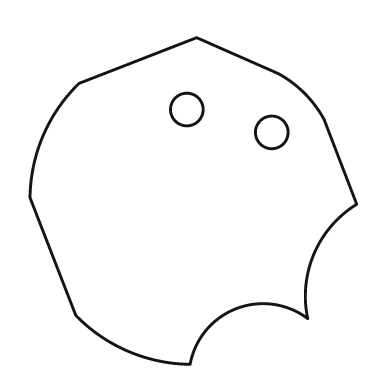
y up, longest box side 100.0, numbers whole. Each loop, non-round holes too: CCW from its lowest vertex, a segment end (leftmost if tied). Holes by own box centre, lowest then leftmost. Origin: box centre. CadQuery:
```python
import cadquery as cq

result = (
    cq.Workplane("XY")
    .moveTo(-1.0, -50.0)
    .threePointArc((13.0, -33.0), (35.0, -36.0))
    .threePointArc((37.0, -16.0), (50.0, -1.0))
    .lineTo(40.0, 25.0)
    .threePointArc((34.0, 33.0), (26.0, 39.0))
    .lineTo(1.0, 50.0)
    .lineTo(-35.0, 36.0)
    .threePointArc((-46.0, 20.0), (-50.0, 1.0))
    .lineTo(-36.0, -35.0)
    .threePointArc((-20.0, -46.0), (-1.0, -50.0))
    .close()
    .moveTo(24.0, 21.0)
    .circle(5.0)
    .moveTo(-2.0, 28.0)
    .circle(5.0)
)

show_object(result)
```